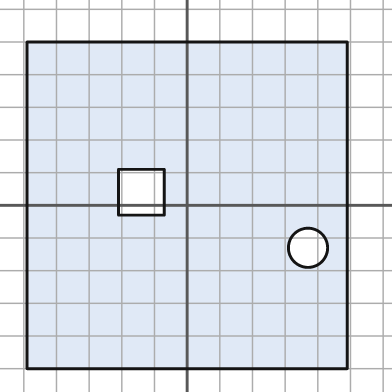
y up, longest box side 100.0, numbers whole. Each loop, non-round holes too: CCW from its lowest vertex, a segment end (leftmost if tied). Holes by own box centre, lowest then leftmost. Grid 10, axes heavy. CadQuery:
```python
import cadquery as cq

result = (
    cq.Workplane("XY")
    .moveTo(-49.0, -50.0)
    .lineTo(49.0, -50.0)
    .lineTo(49.0, 50.0)
    .lineTo(-49.0, 50.0)
    .close()
    .moveTo(37.0, -13.0)
    .circle(6.0)
    .moveTo(-21.0, -3.0)
    .lineTo(-7.0, -3.0)
    .lineTo(-7.0, 11.0)
    .lineTo(-21.0, 11.0)
    .close()
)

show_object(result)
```